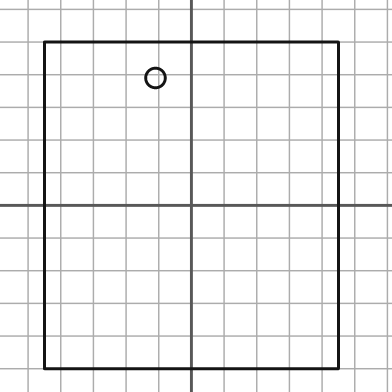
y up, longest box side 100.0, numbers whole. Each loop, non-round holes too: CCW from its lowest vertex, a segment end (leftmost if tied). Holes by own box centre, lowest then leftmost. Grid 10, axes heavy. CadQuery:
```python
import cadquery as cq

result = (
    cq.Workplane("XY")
    .moveTo(-45.0, -50.0)
    .lineTo(45.0, -50.0)
    .lineTo(45.0, 50.0)
    .lineTo(-45.0, 50.0)
    .close()
    .moveTo(-11.0, 39.0)
    .circle(3.0)
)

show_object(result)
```